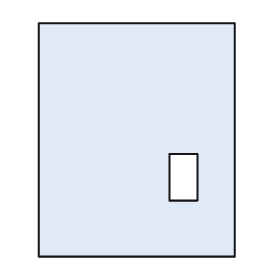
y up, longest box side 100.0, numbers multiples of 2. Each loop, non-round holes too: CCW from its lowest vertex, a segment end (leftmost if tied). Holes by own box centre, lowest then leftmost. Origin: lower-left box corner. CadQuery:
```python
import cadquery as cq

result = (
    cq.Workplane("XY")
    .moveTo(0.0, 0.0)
    .lineTo(84.0, 0.0)
    .lineTo(84.0, 100.0)
    .lineTo(0.0, 100.0)
    .close()
    .moveTo(56.0, 24.0)
    .lineTo(68.0, 24.0)
    .lineTo(68.0, 44.0)
    .lineTo(56.0, 44.0)
    .close()
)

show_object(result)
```